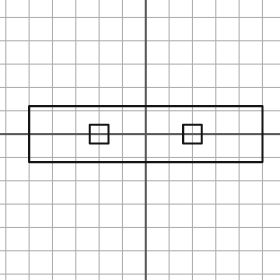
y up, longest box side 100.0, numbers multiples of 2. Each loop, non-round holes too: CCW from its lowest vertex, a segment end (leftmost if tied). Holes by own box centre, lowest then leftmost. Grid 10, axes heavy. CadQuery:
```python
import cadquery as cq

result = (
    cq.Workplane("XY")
    .moveTo(-50.0, -12.0)
    .lineTo(50.0, -12.0)
    .lineTo(50.0, 12.0)
    .lineTo(-50.0, 12.0)
    .close()
    .moveTo(-24.0, -4.0)
    .lineTo(-16.0, -4.0)
    .lineTo(-16.0, 4.0)
    .lineTo(-24.0, 4.0)
    .close()
    .moveTo(16.0, -4.0)
    .lineTo(24.0, -4.0)
    .lineTo(24.0, 4.0)
    .lineTo(16.0, 4.0)
    .close()
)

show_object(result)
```